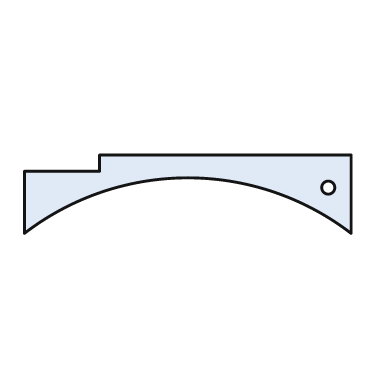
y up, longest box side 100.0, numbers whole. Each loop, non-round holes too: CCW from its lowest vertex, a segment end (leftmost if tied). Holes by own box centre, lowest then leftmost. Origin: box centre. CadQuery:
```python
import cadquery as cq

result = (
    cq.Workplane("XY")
    .moveTo(-50.0, -12.0)
    .threePointArc((0.0, 5.0), (50.0, -12.0))
    .lineTo(50.0, 12.0)
    .lineTo(-27.0, 12.0)
    .lineTo(-27.0, 7.0)
    .lineTo(-50.0, 7.0)
    .close()
    .moveTo(43.0, 2.0)
    .circle(2.0)
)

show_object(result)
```